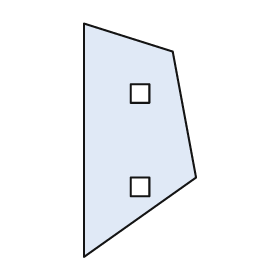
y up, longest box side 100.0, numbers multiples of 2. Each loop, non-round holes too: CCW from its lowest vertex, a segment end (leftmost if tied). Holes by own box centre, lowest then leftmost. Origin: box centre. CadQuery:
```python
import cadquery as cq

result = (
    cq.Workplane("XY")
    .moveTo(-24.0, -50.0)
    .lineTo(24.0, -16.0)
    .lineTo(14.0, 38.0)
    .lineTo(-24.0, 50.0)
    .close()
    .moveTo(-4.0, -24.0)
    .lineTo(4.0, -24.0)
    .lineTo(4.0, -16.0)
    .lineTo(-4.0, -16.0)
    .close()
    .moveTo(-4.0, 16.0)
    .lineTo(4.0, 16.0)
    .lineTo(4.0, 24.0)
    .lineTo(-4.0, 24.0)
    .close()
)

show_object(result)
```